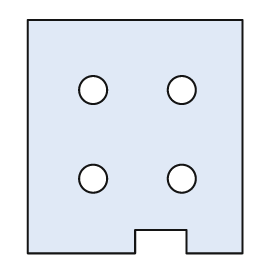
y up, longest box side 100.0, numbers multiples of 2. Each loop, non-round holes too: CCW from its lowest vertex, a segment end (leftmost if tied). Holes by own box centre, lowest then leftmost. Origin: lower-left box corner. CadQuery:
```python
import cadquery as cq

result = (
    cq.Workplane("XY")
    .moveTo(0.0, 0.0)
    .lineTo(46.0, 0.0)
    .lineTo(46.0, 10.0)
    .lineTo(68.0, 10.0)
    .lineTo(68.0, 0.0)
    .lineTo(92.0, 0.0)
    .lineTo(92.0, 100.0)
    .lineTo(0.0, 100.0)
    .close()
    .moveTo(28.0, 32.0)
    .circle(6.0)
    .moveTo(66.0, 32.0)
    .circle(6.0)
    .moveTo(28.0, 70.0)
    .circle(6.0)
    .moveTo(66.0, 70.0)
    .circle(6.0)
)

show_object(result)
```